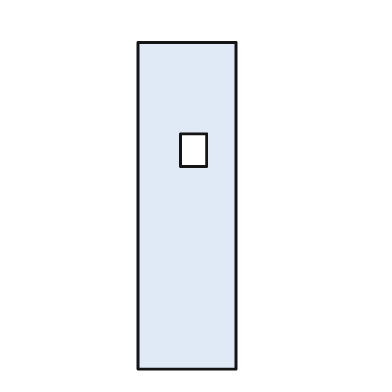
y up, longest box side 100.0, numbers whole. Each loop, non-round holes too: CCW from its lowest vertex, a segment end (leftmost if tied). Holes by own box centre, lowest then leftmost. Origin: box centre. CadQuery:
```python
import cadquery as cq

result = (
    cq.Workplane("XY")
    .moveTo(-15.0, -50.0)
    .lineTo(15.0, -50.0)
    .lineTo(15.0, 50.0)
    .lineTo(-15.0, 50.0)
    .close()
    .moveTo(-2.0, 12.0)
    .lineTo(6.0, 12.0)
    .lineTo(6.0, 22.0)
    .lineTo(-2.0, 22.0)
    .close()
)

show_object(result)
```